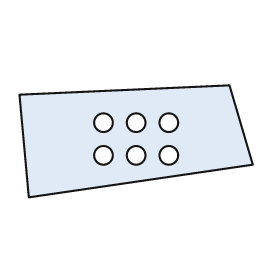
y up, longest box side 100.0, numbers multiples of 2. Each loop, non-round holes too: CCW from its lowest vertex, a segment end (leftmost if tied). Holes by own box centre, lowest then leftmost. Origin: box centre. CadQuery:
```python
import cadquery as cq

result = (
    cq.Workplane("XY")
    .moveTo(-46.0, -24.0)
    .lineTo(50.0, -10.0)
    .lineTo(40.0, 24.0)
    .lineTo(-50.0, 20.0)
    .close()
    .moveTo(-14.0, -6.0)
    .circle(4.0)
    .moveTo(0.0, -6.0)
    .circle(4.0)
    .moveTo(14.0, -6.0)
    .circle(4.0)
    .moveTo(-14.0, 8.0)
    .circle(4.0)
    .moveTo(0.0, 8.0)
    .circle(4.0)
    .moveTo(14.0, 8.0)
    .circle(4.0)
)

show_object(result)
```